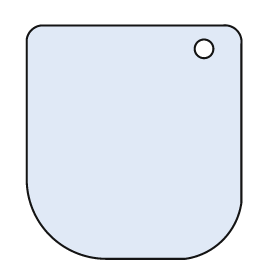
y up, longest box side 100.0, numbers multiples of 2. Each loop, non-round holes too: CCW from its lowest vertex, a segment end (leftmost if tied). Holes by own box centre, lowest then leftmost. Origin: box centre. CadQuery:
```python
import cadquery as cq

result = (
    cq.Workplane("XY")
    .moveTo(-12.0, -50.0)
    .lineTo(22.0, -50.0)
    .threePointArc((38.0, -42.0), (46.0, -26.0))
    .lineTo(46.0, 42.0)
    .threePointArc((44.0, 48.0), (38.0, 50.0))
    .lineTo(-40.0, 50.0)
    .threePointArc((-44.0, 48.0), (-46.0, 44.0))
    .lineTo(-46.0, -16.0)
    .threePointArc((-36.0, -40.0), (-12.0, -50.0))
    .close()
    .moveTo(30.0, 40.0)
    .circle(4.0)
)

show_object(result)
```